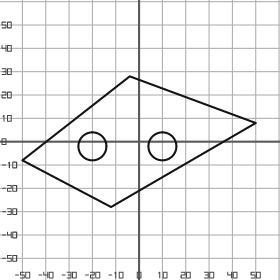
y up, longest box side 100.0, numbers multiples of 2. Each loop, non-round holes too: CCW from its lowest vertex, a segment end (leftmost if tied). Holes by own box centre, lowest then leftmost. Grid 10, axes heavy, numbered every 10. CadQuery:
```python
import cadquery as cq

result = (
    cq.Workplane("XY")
    .moveTo(-12.0, -28.0)
    .lineTo(50.0, 8.0)
    .lineTo(-4.0, 28.0)
    .lineTo(-50.0, -8.0)
    .close()
    .moveTo(-20.0, -2.0)
    .circle(6.0)
    .moveTo(10.0, -2.0)
    .circle(6.0)
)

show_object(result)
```